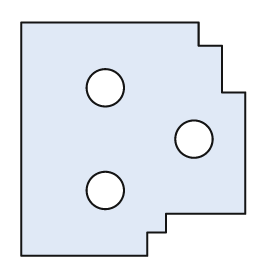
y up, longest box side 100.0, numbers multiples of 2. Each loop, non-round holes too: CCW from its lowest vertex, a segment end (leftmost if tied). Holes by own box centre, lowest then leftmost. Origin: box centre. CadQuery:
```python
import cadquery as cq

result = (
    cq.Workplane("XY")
    .moveTo(-48.0, -50.0)
    .lineTo(6.0, -50.0)
    .lineTo(6.0, -40.0)
    .lineTo(14.0, -40.0)
    .lineTo(14.0, -32.0)
    .lineTo(48.0, -32.0)
    .lineTo(48.0, 20.0)
    .lineTo(38.0, 20.0)
    .lineTo(38.0, 40.0)
    .lineTo(28.0, 40.0)
    .lineTo(28.0, 50.0)
    .lineTo(-48.0, 50.0)
    .close()
    .moveTo(-12.0, -22.0)
    .circle(8.0)
    .moveTo(26.0, 0.0)
    .circle(8.0)
    .moveTo(-12.0, 22.0)
    .circle(8.0)
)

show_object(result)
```